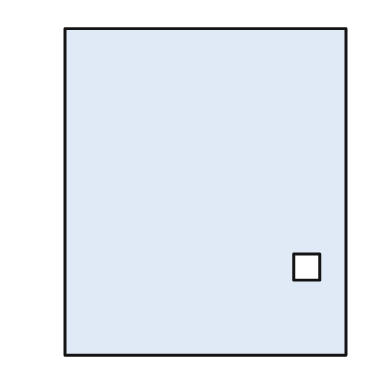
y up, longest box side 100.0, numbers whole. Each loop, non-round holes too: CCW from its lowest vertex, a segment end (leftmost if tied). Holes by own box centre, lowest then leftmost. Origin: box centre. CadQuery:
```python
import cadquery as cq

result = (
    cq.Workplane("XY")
    .moveTo(-43.0, -50.0)
    .lineTo(43.0, -50.0)
    .lineTo(43.0, 50.0)
    .lineTo(-43.0, 50.0)
    .close()
    .moveTo(27.0, -27.0)
    .lineTo(35.0, -27.0)
    .lineTo(35.0, -19.0)
    .lineTo(27.0, -19.0)
    .close()
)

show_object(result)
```